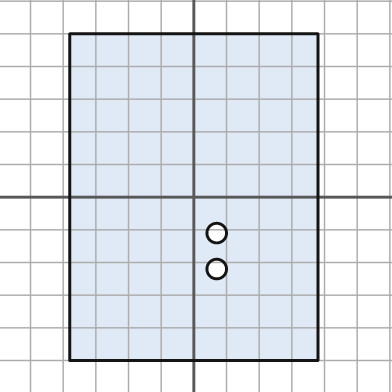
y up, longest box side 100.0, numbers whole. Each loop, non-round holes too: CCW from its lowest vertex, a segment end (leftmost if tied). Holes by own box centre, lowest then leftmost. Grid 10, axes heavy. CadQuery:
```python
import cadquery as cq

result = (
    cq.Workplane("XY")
    .moveTo(-38.0, -50.0)
    .lineTo(38.0, -50.0)
    .lineTo(38.0, 50.0)
    .lineTo(-38.0, 50.0)
    .close()
    .moveTo(7.0, -22.0)
    .circle(3.0)
    .moveTo(7.0, -11.0)
    .circle(3.0)
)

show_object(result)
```